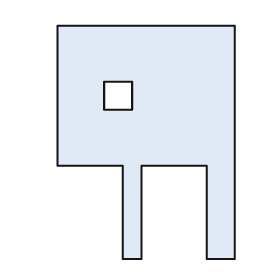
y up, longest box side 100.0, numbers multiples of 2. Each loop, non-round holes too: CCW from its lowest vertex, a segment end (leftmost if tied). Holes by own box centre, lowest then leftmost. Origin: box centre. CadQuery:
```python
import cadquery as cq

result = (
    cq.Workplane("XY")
    .moveTo(-10.0, -50.0)
    .lineTo(-2.0, -50.0)
    .lineTo(-2.0, -10.0)
    .lineTo(26.0, -10.0)
    .lineTo(26.0, -50.0)
    .lineTo(38.0, -50.0)
    .lineTo(38.0, 50.0)
    .lineTo(-38.0, 50.0)
    .lineTo(-38.0, -10.0)
    .lineTo(-10.0, -10.0)
    .close()
    .moveTo(-18.0, 14.0)
    .lineTo(-6.0, 14.0)
    .lineTo(-6.0, 26.0)
    .lineTo(-18.0, 26.0)
    .close()
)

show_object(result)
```